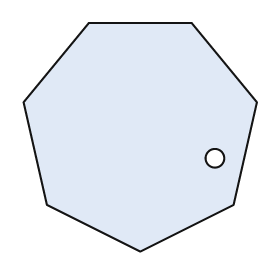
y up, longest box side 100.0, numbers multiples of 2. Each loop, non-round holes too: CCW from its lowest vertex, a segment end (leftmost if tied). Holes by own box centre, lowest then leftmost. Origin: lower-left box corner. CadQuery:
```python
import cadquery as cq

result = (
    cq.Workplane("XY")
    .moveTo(50.0, 0.0)
    .lineTo(90.0, 20.0)
    .lineTo(100.0, 64.0)
    .lineTo(72.0, 98.0)
    .lineTo(28.0, 98.0)
    .lineTo(0.0, 64.0)
    .lineTo(10.0, 20.0)
    .close()
    .moveTo(82.0, 40.0)
    .circle(4.0)
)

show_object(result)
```